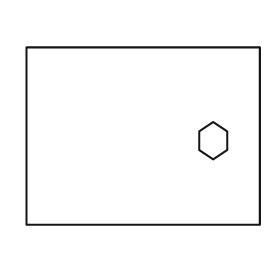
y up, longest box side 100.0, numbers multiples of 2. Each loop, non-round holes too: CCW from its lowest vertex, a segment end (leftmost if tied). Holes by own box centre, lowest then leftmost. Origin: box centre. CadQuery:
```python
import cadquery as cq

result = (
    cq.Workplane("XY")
    .moveTo(-50.0, -38.0)
    .lineTo(50.0, -38.0)
    .lineTo(50.0, 38.0)
    .lineTo(-50.0, 38.0)
    .close()
    .moveTo(30.0, -10.0)
    .lineTo(36.0, -6.0)
    .lineTo(36.0, 2.0)
    .lineTo(30.0, 6.0)
    .lineTo(24.0, 2.0)
    .lineTo(24.0, -6.0)
    .close()
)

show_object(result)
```